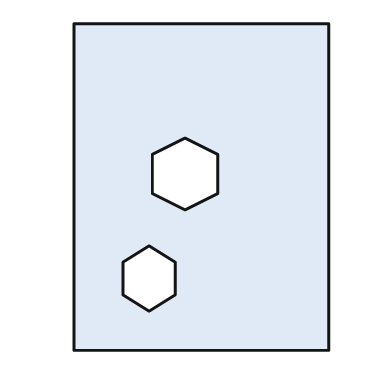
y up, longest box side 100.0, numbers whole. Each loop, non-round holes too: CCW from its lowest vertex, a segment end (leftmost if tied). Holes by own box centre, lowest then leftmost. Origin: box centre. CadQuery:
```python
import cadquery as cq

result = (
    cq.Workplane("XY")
    .moveTo(-39.0, -50.0)
    .lineTo(39.0, -50.0)
    .lineTo(39.0, 50.0)
    .lineTo(-39.0, 50.0)
    .close()
    .moveTo(-16.0, -38.0)
    .lineTo(-8.0, -33.0)
    .lineTo(-8.0, -23.0)
    .lineTo(-16.0, -18.0)
    .lineTo(-24.0, -23.0)
    .lineTo(-24.0, -33.0)
    .close()
    .moveTo(-5.0, -7.0)
    .lineTo(5.0, -2.0)
    .lineTo(5.0, 10.0)
    .lineTo(-5.0, 15.0)
    .lineTo(-15.0, 10.0)
    .lineTo(-15.0, -2.0)
    .close()
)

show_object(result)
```